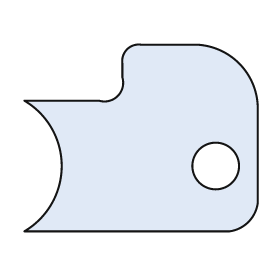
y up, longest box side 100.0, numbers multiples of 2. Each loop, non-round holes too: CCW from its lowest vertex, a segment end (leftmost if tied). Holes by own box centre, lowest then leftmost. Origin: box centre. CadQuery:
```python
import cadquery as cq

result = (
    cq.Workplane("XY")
    .moveTo(-50.0, -40.0)
    .lineTo(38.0, -40.0)
    .threePointArc((46.0, -36.0), (50.0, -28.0))
    .lineTo(50.0, 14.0)
    .threePointArc((42.0, 32.0), (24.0, 40.0))
    .lineTo(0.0, 40.0)
    .threePointArc((-6.0, 38.0), (-8.0, 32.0))
    .lineTo(-8.0, 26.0)
    .threePointArc((-10.0, 18.0), (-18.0, 16.0))
    .lineTo(-50.0, 16.0)
    .threePointArc((-34.0, -12.0), (-50.0, -40.0))
    .close()
    .moveTo(32.0, -12.0)
    .circle(10.0)
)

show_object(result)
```